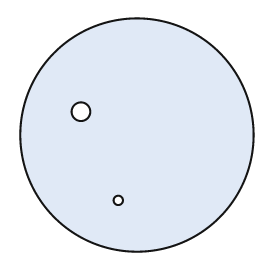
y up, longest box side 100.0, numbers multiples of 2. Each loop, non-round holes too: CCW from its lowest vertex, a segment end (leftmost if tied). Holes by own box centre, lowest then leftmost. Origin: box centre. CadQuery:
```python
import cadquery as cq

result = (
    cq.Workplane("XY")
    .moveTo(0.0, 0.0)
    .circle(50.0)
    .moveTo(-8.0, -28.0)
    .circle(2.0)
    .moveTo(-24.0, 10.0)
    .circle(4.0)
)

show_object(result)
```